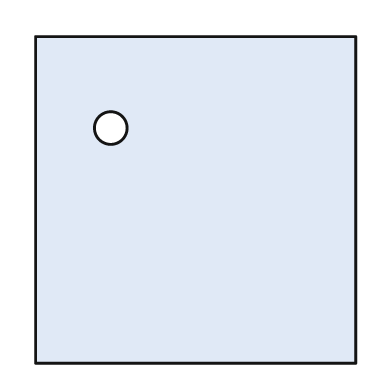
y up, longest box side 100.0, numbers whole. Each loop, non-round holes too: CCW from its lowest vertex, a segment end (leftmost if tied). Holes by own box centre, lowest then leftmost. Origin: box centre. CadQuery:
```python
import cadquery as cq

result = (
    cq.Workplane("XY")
    .moveTo(-49.0, -50.0)
    .lineTo(49.0, -50.0)
    .lineTo(49.0, 50.0)
    .lineTo(-49.0, 50.0)
    .close()
    .moveTo(-26.0, 22.0)
    .circle(5.0)
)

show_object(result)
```